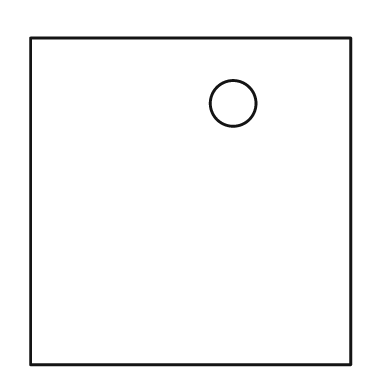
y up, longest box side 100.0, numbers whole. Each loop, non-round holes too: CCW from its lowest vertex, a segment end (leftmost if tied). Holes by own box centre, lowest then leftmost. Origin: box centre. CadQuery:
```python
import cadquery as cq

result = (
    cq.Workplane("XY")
    .moveTo(-49.0, -50.0)
    .lineTo(49.0, -50.0)
    .lineTo(49.0, 50.0)
    .lineTo(-49.0, 50.0)
    .close()
    .moveTo(13.0, 30.0)
    .circle(7.0)
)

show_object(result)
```